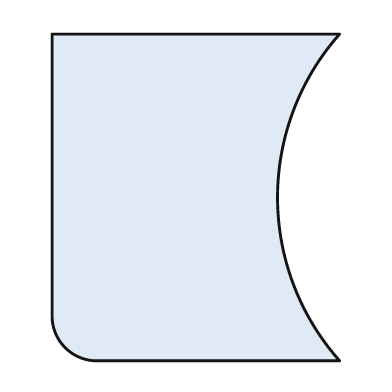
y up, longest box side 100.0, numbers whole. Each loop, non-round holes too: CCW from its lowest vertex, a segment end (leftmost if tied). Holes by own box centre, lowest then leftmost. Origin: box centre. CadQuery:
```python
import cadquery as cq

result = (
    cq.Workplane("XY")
    .moveTo(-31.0, -50.0)
    .lineTo(44.0, -50.0)
    .threePointArc((25.0, 0.0), (44.0, 50.0))
    .lineTo(-44.0, 50.0)
    .lineTo(-44.0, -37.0)
    .threePointArc((-40.0, -46.0), (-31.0, -50.0))
    .close()
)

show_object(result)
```